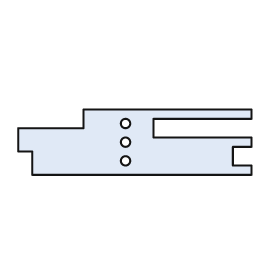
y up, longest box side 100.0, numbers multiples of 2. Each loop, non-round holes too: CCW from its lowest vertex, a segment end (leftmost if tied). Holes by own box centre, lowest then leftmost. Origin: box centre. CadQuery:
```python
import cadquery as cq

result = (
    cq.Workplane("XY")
    .moveTo(-44.0, -14.0)
    .lineTo(50.0, -14.0)
    .lineTo(50.0, -10.0)
    .lineTo(42.0, -10.0)
    .lineTo(42.0, -2.0)
    .lineTo(50.0, -2.0)
    .lineTo(50.0, 2.0)
    .lineTo(8.0, 2.0)
    .lineTo(8.0, 10.0)
    .lineTo(50.0, 10.0)
    .lineTo(50.0, 14.0)
    .lineTo(-22.0, 14.0)
    .lineTo(-22.0, 6.0)
    .lineTo(-50.0, 6.0)
    .lineTo(-50.0, -4.0)
    .lineTo(-44.0, -4.0)
    .close()
    .moveTo(-4.0, -8.0)
    .circle(2.0)
    .moveTo(-4.0, 0.0)
    .circle(2.0)
    .moveTo(-4.0, 8.0)
    .circle(2.0)
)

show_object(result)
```